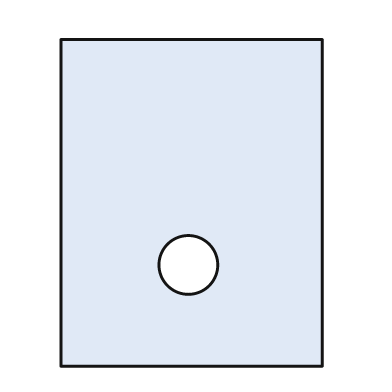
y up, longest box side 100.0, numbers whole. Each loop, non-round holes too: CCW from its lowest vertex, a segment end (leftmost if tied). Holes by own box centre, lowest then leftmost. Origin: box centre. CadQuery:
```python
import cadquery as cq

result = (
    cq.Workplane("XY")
    .moveTo(-40.0, -50.0)
    .lineTo(40.0, -50.0)
    .lineTo(40.0, 50.0)
    .lineTo(-40.0, 50.0)
    .close()
    .moveTo(-1.0, -19.0)
    .circle(9.0)
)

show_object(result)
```